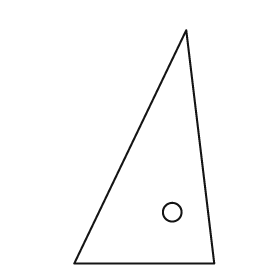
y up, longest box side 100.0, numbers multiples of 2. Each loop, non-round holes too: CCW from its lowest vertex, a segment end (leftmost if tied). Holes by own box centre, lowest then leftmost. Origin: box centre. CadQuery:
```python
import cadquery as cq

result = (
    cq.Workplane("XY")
    .moveTo(-30.0, -50.0)
    .lineTo(30.0, -50.0)
    .lineTo(18.0, 50.0)
    .close()
    .moveTo(12.0, -28.0)
    .circle(4.0)
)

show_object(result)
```